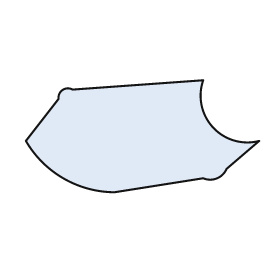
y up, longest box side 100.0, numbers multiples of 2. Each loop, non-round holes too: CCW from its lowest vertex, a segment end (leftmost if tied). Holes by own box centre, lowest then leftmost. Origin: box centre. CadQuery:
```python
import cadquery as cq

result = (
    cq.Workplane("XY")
    .moveTo(-12.0, -24.0)
    .lineTo(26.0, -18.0)
    .threePointArc((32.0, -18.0), (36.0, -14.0))
    .lineTo(50.0, -2.0)
    .threePointArc((30.0, 4.0), (26.0, 24.0))
    .lineTo(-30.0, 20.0)
    .threePointArc((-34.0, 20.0), (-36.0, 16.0))
    .lineTo(-50.0, -2.0)
    .threePointArc((-34.0, -18.0), (-12.0, -24.0))
    .close()
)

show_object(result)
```